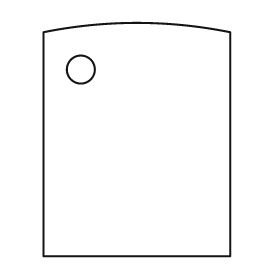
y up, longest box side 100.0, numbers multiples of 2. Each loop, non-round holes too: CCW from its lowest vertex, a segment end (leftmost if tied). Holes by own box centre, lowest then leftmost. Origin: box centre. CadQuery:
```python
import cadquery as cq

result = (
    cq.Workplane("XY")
    .moveTo(-40.0, -50.0)
    .lineTo(40.0, -50.0)
    .lineTo(40.0, 46.0)
    .threePointArc((0.0, 50.0), (-40.0, 46.0))
    .close()
    .moveTo(-24.0, 30.0)
    .circle(6.0)
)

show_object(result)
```